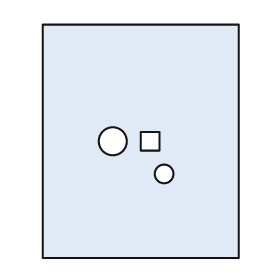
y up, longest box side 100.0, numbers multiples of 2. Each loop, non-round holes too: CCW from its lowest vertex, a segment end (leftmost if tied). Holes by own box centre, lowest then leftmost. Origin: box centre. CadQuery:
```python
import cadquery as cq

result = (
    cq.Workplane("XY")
    .moveTo(-42.0, -50.0)
    .lineTo(42.0, -50.0)
    .lineTo(42.0, 50.0)
    .lineTo(-42.0, 50.0)
    .close()
    .moveTo(10.0, -14.0)
    .circle(4.0)
    .moveTo(-12.0, 0.0)
    .circle(6.0)
    .moveTo(0.0, -4.0)
    .lineTo(8.0, -4.0)
    .lineTo(8.0, 4.0)
    .lineTo(0.0, 4.0)
    .close()
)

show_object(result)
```